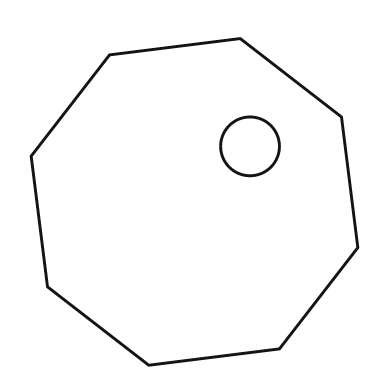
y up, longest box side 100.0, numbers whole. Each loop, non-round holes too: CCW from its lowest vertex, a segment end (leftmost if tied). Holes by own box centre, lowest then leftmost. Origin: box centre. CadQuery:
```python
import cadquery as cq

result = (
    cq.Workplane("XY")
    .moveTo(-14.0, -50.0)
    .lineTo(26.0, -45.0)
    .lineTo(50.0, -14.0)
    .lineTo(45.0, 26.0)
    .lineTo(14.0, 50.0)
    .lineTo(-26.0, 45.0)
    .lineTo(-50.0, 14.0)
    .lineTo(-45.0, -26.0)
    .close()
    .moveTo(17.0, 17.0)
    .circle(9.0)
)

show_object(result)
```